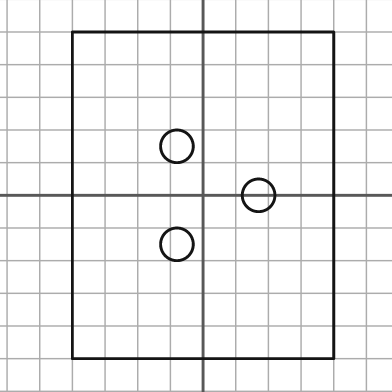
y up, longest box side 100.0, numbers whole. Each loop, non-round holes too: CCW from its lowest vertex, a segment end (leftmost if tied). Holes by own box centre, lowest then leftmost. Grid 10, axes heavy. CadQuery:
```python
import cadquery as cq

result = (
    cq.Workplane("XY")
    .moveTo(-40.0, -50.0)
    .lineTo(40.0, -50.0)
    .lineTo(40.0, 50.0)
    .lineTo(-40.0, 50.0)
    .close()
    .moveTo(-8.0, -15.0)
    .circle(5.0)
    .moveTo(17.0, 0.0)
    .circle(5.0)
    .moveTo(-8.0, 15.0)
    .circle(5.0)
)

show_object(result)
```